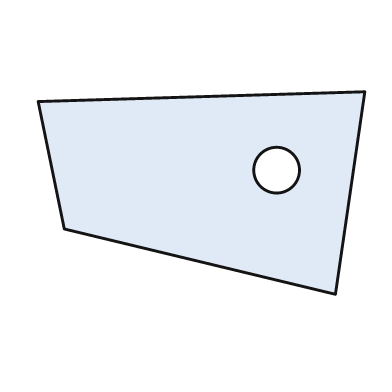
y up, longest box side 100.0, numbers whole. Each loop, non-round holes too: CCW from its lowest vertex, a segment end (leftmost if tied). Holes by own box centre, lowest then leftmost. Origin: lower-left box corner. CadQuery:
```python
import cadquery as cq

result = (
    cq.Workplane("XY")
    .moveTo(91.0, 0.0)
    .lineTo(100.0, 62.0)
    .lineTo(0.0, 59.0)
    .lineTo(8.0, 20.0)
    .close()
    .moveTo(73.0, 38.0)
    .circle(7.0)
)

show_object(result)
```